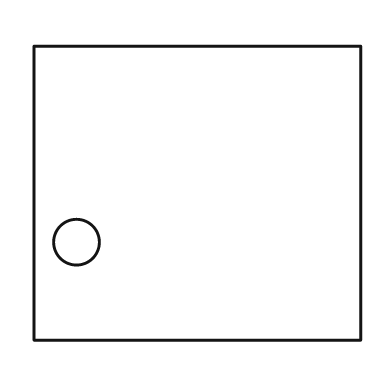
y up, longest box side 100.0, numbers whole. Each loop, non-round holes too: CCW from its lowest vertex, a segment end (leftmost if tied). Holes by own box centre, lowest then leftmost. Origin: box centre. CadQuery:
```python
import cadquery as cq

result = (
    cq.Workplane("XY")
    .moveTo(-50.0, -45.0)
    .lineTo(50.0, -45.0)
    .lineTo(50.0, 45.0)
    .lineTo(-50.0, 45.0)
    .close()
    .moveTo(-37.0, -15.0)
    .circle(7.0)
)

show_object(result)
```